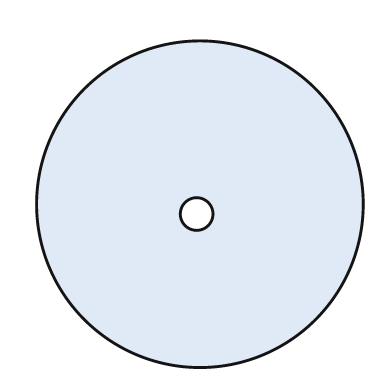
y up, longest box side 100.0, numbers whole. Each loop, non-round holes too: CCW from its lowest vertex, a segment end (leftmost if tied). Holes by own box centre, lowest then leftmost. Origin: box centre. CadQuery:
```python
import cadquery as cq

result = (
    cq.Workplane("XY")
    .moveTo(0.0, 0.0)
    .circle(50.0)
    .moveTo(-1.0, -3.0)
    .circle(5.0)
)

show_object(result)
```